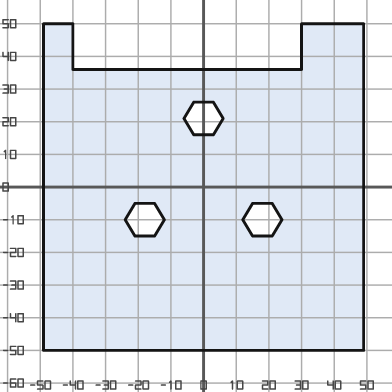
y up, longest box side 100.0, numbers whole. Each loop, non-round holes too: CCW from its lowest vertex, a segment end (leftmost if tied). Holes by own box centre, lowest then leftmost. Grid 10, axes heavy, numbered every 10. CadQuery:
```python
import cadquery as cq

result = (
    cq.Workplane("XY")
    .moveTo(-49.0, -50.0)
    .lineTo(49.0, -50.0)
    .lineTo(49.0, 50.0)
    .lineTo(30.0, 50.0)
    .lineTo(30.0, 36.0)
    .lineTo(-40.0, 36.0)
    .lineTo(-40.0, 50.0)
    .lineTo(-49.0, 50.0)
    .close()
    .moveTo(-21.0, -15.0)
    .lineTo(-15.0, -15.0)
    .lineTo(-12.0, -10.0)
    .lineTo(-15.0, -5.0)
    .lineTo(-21.0, -5.0)
    .lineTo(-24.0, -10.0)
    .close()
    .moveTo(15.0, -15.0)
    .lineTo(21.0, -15.0)
    .lineTo(24.0, -10.0)
    .lineTo(21.0, -5.0)
    .lineTo(15.0, -5.0)
    .lineTo(12.0, -10.0)
    .close()
    .moveTo(-3.0, 16.0)
    .lineTo(3.0, 16.0)
    .lineTo(6.0, 21.0)
    .lineTo(3.0, 26.0)
    .lineTo(-3.0, 26.0)
    .lineTo(-6.0, 21.0)
    .close()
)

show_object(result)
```